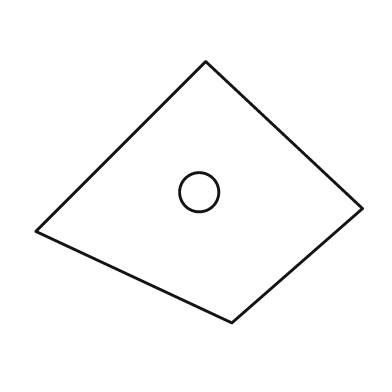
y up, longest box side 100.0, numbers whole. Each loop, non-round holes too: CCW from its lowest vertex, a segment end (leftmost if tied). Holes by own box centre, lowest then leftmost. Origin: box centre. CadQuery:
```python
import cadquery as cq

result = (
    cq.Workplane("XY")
    .moveTo(10.0, -40.0)
    .lineTo(50.0, -5.0)
    .lineTo(2.0, 40.0)
    .lineTo(-50.0, -12.0)
    .close()
    .moveTo(0.0, 0.0)
    .circle(6.0)
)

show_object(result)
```